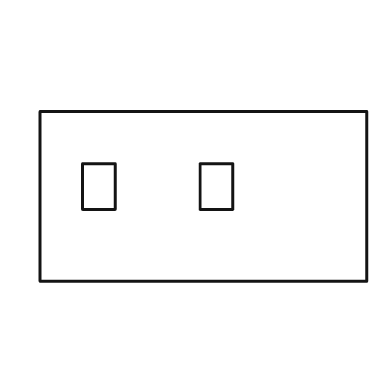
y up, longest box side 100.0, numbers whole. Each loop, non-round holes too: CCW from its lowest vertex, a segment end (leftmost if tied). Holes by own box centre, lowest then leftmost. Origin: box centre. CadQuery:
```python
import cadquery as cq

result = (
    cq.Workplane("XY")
    .moveTo(-50.0, -26.0)
    .lineTo(50.0, -26.0)
    .lineTo(50.0, 26.0)
    .lineTo(-50.0, 26.0)
    .close()
    .moveTo(-37.0, -4.0)
    .lineTo(-27.0, -4.0)
    .lineTo(-27.0, 10.0)
    .lineTo(-37.0, 10.0)
    .close()
    .moveTo(-1.0, -4.0)
    .lineTo(9.0, -4.0)
    .lineTo(9.0, 10.0)
    .lineTo(-1.0, 10.0)
    .close()
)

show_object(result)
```